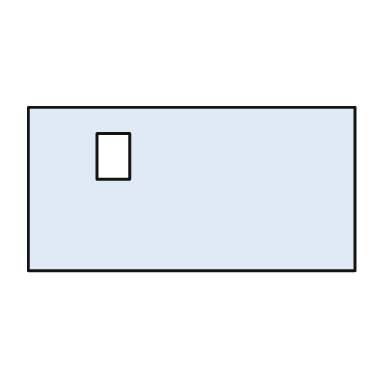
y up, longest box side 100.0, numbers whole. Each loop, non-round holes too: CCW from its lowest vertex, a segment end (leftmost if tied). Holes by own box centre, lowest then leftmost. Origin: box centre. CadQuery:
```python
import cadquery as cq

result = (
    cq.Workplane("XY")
    .moveTo(-50.0, -25.0)
    .lineTo(50.0, -25.0)
    .lineTo(50.0, 25.0)
    .lineTo(-50.0, 25.0)
    .close()
    .moveTo(-29.0, 3.0)
    .lineTo(-19.0, 3.0)
    .lineTo(-19.0, 17.0)
    .lineTo(-29.0, 17.0)
    .close()
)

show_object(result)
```